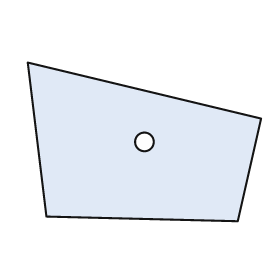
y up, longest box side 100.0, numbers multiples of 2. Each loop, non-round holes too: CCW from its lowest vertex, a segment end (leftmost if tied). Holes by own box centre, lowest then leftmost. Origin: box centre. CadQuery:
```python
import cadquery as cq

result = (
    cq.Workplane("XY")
    .moveTo(40.0, -34.0)
    .lineTo(50.0, 10.0)
    .lineTo(-50.0, 34.0)
    .lineTo(-42.0, -32.0)
    .close()
    .moveTo(0.0, 0.0)
    .circle(4.0)
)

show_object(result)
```